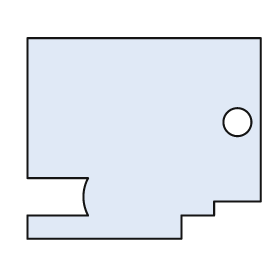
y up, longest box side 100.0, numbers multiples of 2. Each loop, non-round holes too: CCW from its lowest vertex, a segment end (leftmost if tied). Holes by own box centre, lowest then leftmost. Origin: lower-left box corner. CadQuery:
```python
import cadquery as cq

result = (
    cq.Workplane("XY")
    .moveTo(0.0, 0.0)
    .lineTo(66.0, 0.0)
    .lineTo(66.0, 10.0)
    .lineTo(80.0, 10.0)
    .lineTo(80.0, 16.0)
    .lineTo(100.0, 16.0)
    .lineTo(100.0, 86.0)
    .lineTo(0.0, 86.0)
    .lineTo(0.0, 26.0)
    .lineTo(26.0, 26.0)
    .threePointArc((24.0, 18.0), (26.0, 10.0))
    .lineTo(0.0, 10.0)
    .close()
    .moveTo(90.0, 50.0)
    .circle(6.0)
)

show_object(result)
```